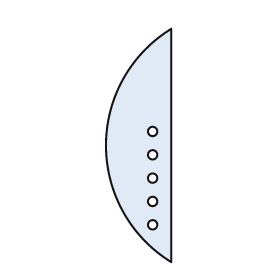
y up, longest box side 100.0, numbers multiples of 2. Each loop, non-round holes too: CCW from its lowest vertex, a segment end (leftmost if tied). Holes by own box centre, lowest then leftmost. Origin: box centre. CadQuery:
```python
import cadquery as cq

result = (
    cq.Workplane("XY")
    .moveTo(14.0, -50.0)
    .lineTo(14.0, 50.0)
    .threePointArc((-14.0, 0.0), (14.0, -50.0))
    .close()
    .moveTo(6.0, -34.0)
    .circle(2.0)
    .moveTo(6.0, -24.0)
    .circle(2.0)
    .moveTo(6.0, -14.0)
    .circle(2.0)
    .moveTo(6.0, -4.0)
    .circle(2.0)
    .moveTo(6.0, 6.0)
    .circle(2.0)
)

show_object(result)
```